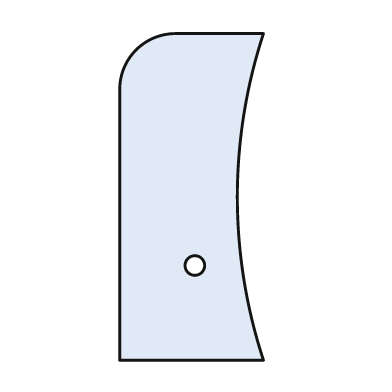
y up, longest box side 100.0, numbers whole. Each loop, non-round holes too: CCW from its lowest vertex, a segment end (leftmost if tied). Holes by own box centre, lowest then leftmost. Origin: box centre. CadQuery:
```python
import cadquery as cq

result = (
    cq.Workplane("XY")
    .moveTo(-22.0, -50.0)
    .lineTo(22.0, -50.0)
    .threePointArc((14.0, 0.0), (22.0, 50.0))
    .lineTo(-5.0, 50.0)
    .threePointArc((-17.0, 45.0), (-22.0, 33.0))
    .close()
    .moveTo(1.0, -21.0)
    .circle(3.0)
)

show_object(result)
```